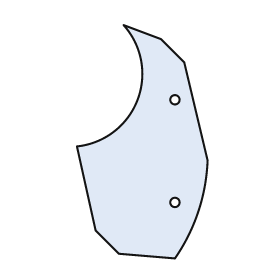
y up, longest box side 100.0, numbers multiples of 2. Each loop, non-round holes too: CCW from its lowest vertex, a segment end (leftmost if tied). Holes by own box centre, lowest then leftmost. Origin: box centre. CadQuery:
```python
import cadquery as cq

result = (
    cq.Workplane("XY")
    .moveTo(14.0, -50.0)
    .threePointArc((24.0, -30.0), (28.0, -8.0))
    .lineTo(18.0, 34.0)
    .lineTo(8.0, 44.0)
    .lineTo(-8.0, 50.0)
    .threePointArc((-2.0, 18.0), (-28.0, -2.0))
    .lineTo(-20.0, -38.0)
    .lineTo(-10.0, -48.0)
    .close()
    .moveTo(14.0, -26.0)
    .circle(2.0)
    .moveTo(14.0, 18.0)
    .circle(2.0)
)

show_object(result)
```